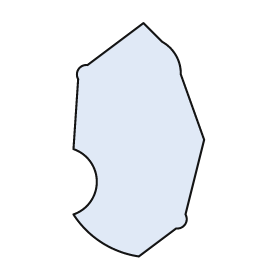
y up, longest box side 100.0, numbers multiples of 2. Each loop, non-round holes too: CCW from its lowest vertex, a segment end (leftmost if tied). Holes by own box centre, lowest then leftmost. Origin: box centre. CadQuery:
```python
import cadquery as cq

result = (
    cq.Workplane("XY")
    .moveTo(0.0, -50.0)
    .lineTo(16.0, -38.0)
    .threePointArc((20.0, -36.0), (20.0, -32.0))
    .lineTo(28.0, 0.0)
    .lineTo(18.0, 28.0)
    .threePointArc((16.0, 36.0), (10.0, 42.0))
    .lineTo(2.0, 50.0)
    .lineTo(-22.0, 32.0)
    .threePointArc((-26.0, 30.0), (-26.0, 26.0))
    .lineTo(-28.0, -4.0)
    .threePointArc((-18.0, -18.0), (-28.0, -32.0))
    .threePointArc((-16.0, -44.0), (0.0, -50.0))
    .close()
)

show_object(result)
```